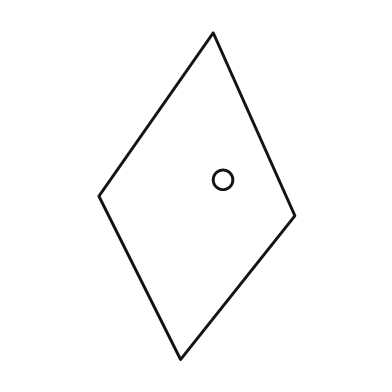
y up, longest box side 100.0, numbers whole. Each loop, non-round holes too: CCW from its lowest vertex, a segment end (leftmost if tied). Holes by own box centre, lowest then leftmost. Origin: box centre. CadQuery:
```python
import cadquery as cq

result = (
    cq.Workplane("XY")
    .moveTo(-5.0, -50.0)
    .lineTo(30.0, -6.0)
    .lineTo(5.0, 50.0)
    .lineTo(-30.0, 0.0)
    .close()
    .moveTo(8.0, 5.0)
    .circle(3.0)
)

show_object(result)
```